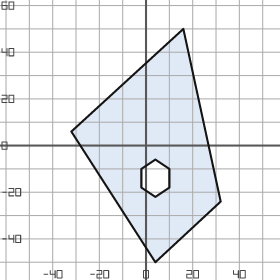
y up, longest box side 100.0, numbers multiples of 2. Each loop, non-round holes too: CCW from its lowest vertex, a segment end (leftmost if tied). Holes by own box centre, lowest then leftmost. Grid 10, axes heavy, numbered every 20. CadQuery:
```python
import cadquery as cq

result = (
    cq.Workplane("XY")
    .moveTo(4.0, -50.0)
    .lineTo(32.0, -24.0)
    .lineTo(16.0, 50.0)
    .lineTo(-32.0, 6.0)
    .close()
    .moveTo(4.0, -22.0)
    .lineTo(10.0, -18.0)
    .lineTo(10.0, -10.0)
    .lineTo(4.0, -6.0)
    .lineTo(-2.0, -10.0)
    .lineTo(-2.0, -18.0)
    .close()
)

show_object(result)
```